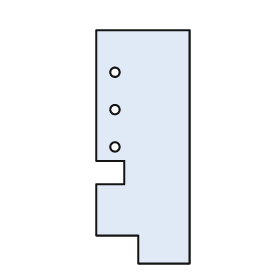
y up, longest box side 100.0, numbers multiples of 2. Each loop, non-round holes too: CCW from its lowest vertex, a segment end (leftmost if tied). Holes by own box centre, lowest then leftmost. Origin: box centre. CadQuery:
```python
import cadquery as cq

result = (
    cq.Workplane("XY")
    .moveTo(-2.0, -50.0)
    .lineTo(20.0, -50.0)
    .lineTo(20.0, 50.0)
    .lineTo(-20.0, 50.0)
    .lineTo(-20.0, -6.0)
    .lineTo(-8.0, -6.0)
    .lineTo(-8.0, -16.0)
    .lineTo(-20.0, -16.0)
    .lineTo(-20.0, -38.0)
    .lineTo(-2.0, -38.0)
    .close()
    .moveTo(-12.0, 0.0)
    .circle(2.0)
    .moveTo(-12.0, 16.0)
    .circle(2.0)
    .moveTo(-12.0, 32.0)
    .circle(2.0)
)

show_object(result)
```